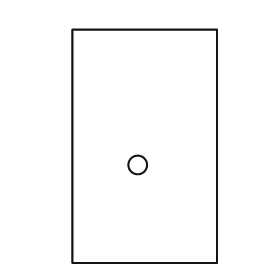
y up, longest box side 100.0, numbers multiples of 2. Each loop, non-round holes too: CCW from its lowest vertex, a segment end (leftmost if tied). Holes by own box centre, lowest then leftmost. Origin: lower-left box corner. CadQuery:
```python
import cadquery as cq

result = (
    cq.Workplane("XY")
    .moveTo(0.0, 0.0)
    .lineTo(62.0, 0.0)
    .lineTo(62.0, 100.0)
    .lineTo(0.0, 100.0)
    .close()
    .moveTo(28.0, 42.0)
    .circle(4.0)
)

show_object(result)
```